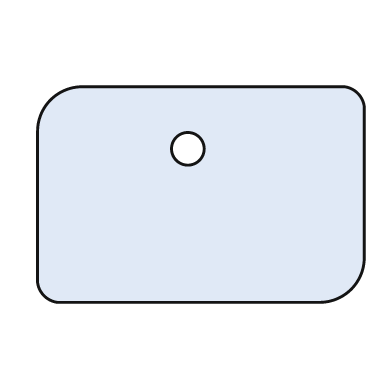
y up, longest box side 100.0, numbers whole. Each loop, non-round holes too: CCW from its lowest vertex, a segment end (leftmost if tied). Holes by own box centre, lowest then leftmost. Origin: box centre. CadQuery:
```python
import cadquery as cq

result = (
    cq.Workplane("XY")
    .moveTo(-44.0, -33.0)
    .lineTo(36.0, -33.0)
    .threePointArc((46.0, -29.0), (50.0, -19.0))
    .lineTo(50.0, 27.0)
    .threePointArc((48.0, 31.0), (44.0, 33.0))
    .lineTo(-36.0, 33.0)
    .threePointArc((-46.0, 29.0), (-50.0, 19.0))
    .lineTo(-50.0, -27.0)
    .threePointArc((-48.0, -31.0), (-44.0, -33.0))
    .close()
    .moveTo(-4.0, 14.0)
    .circle(5.0)
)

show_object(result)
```